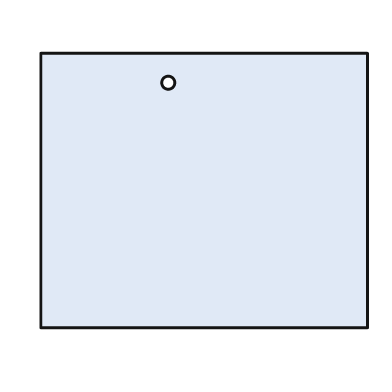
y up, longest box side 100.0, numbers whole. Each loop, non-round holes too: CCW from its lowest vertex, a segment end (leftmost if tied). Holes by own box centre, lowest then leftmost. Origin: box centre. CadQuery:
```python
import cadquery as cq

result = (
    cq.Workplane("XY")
    .moveTo(-50.0, -42.0)
    .lineTo(50.0, -42.0)
    .lineTo(50.0, 42.0)
    .lineTo(-50.0, 42.0)
    .close()
    .moveTo(-11.0, 33.0)
    .circle(2.0)
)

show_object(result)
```